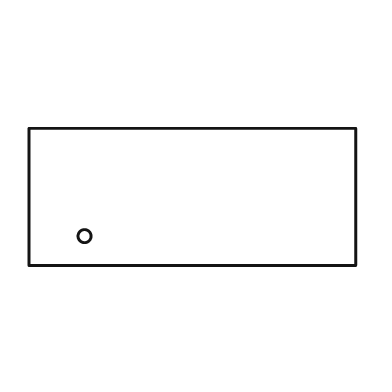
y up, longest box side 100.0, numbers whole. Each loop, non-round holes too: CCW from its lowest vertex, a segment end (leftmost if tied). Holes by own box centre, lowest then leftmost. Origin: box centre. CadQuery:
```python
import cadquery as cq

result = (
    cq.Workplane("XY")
    .moveTo(-50.0, -21.0)
    .lineTo(50.0, -21.0)
    .lineTo(50.0, 21.0)
    .lineTo(-50.0, 21.0)
    .close()
    .moveTo(-33.0, -12.0)
    .circle(2.0)
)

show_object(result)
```